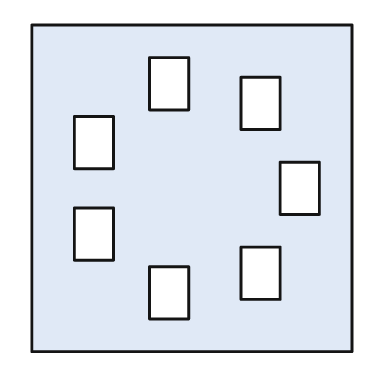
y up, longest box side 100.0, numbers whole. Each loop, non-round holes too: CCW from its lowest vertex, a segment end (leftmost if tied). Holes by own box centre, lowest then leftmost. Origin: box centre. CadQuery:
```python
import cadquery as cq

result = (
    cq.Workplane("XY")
    .moveTo(-49.0, -50.0)
    .lineTo(49.0, -50.0)
    .lineTo(49.0, 50.0)
    .lineTo(-49.0, 50.0)
    .close()
    .moveTo(-13.0, -40.0)
    .lineTo(-1.0, -40.0)
    .lineTo(-1.0, -24.0)
    .lineTo(-13.0, -24.0)
    .close()
    .moveTo(15.0, -34.0)
    .lineTo(27.0, -34.0)
    .lineTo(27.0, -18.0)
    .lineTo(15.0, -18.0)
    .close()
    .moveTo(-36.0, -22.0)
    .lineTo(-24.0, -22.0)
    .lineTo(-24.0, -6.0)
    .lineTo(-36.0, -6.0)
    .close()
    .moveTo(27.0, -8.0)
    .lineTo(39.0, -8.0)
    .lineTo(39.0, 8.0)
    .lineTo(27.0, 8.0)
    .close()
    .moveTo(-36.0, 6.0)
    .lineTo(-24.0, 6.0)
    .lineTo(-24.0, 22.0)
    .lineTo(-36.0, 22.0)
    .close()
    .moveTo(15.0, 18.0)
    .lineTo(27.0, 18.0)
    .lineTo(27.0, 34.0)
    .lineTo(15.0, 34.0)
    .close()
    .moveTo(-13.0, 24.0)
    .lineTo(-1.0, 24.0)
    .lineTo(-1.0, 40.0)
    .lineTo(-13.0, 40.0)
    .close()
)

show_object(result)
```